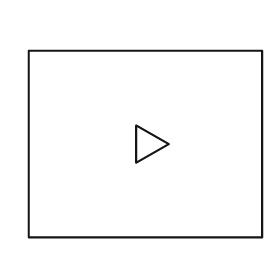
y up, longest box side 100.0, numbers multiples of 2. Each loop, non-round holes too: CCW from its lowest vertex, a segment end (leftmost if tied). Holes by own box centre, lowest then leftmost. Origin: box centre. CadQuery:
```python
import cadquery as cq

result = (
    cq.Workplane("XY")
    .moveTo(-50.0, -40.0)
    .lineTo(50.0, -40.0)
    .lineTo(50.0, 40.0)
    .lineTo(-50.0, 40.0)
    .close()
    .moveTo(-4.0, -8.0)
    .lineTo(10.0, 0.0)
    .lineTo(-4.0, 8.0)
    .close()
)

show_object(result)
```